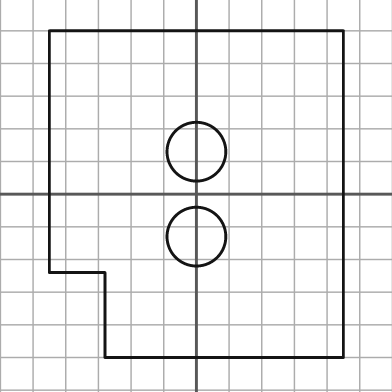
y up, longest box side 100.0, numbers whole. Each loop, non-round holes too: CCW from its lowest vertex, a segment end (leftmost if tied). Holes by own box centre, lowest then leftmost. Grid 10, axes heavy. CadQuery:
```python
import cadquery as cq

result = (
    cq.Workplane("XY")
    .moveTo(-28.0, -50.0)
    .lineTo(45.0, -50.0)
    .lineTo(45.0, 50.0)
    .lineTo(-45.0, 50.0)
    .lineTo(-45.0, -24.0)
    .lineTo(-28.0, -24.0)
    .close()
    .moveTo(0.0, -13.0)
    .circle(9.0)
    .moveTo(0.0, 13.0)
    .circle(9.0)
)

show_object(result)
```